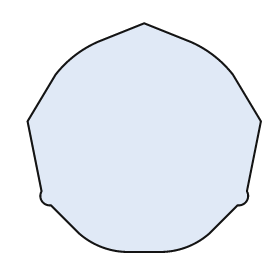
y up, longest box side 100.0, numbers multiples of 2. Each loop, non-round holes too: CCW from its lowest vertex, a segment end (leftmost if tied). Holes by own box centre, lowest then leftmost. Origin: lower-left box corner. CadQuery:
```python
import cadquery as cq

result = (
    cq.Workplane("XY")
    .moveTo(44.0, 0.0)
    .lineTo(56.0, 0.0)
    .threePointArc((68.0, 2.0), (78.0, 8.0))
    .lineTo(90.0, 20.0)
    .threePointArc((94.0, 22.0), (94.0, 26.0))
    .lineTo(100.0, 56.0)
    .lineTo(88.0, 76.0)
    .threePointArc((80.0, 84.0), (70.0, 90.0))
    .lineTo(50.0, 98.0)
    .lineTo(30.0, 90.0)
    .threePointArc((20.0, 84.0), (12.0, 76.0))
    .lineTo(0.0, 56.0)
    .lineTo(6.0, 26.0)
    .threePointArc((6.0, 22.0), (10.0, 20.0))
    .lineTo(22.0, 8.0)
    .threePointArc((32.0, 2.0), (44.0, 0.0))
    .close()
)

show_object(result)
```